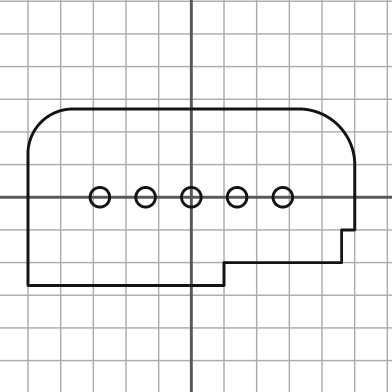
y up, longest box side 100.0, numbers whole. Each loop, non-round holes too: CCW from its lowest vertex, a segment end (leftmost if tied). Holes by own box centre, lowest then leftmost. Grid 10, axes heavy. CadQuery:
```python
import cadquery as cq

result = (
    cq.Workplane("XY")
    .moveTo(-50.0, -27.0)
    .lineTo(10.0, -27.0)
    .lineTo(10.0, -20.0)
    .lineTo(46.0, -20.0)
    .lineTo(46.0, -10.0)
    .lineTo(50.0, -10.0)
    .lineTo(50.0, 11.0)
    .threePointArc((45.0, 22.0), (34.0, 27.0))
    .lineTo(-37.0, 27.0)
    .threePointArc((-46.0, 23.0), (-50.0, 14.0))
    .close()
    .moveTo(-28.0, 0.0)
    .circle(3.0)
    .moveTo(-14.0, 0.0)
    .circle(3.0)
    .moveTo(0.0, 0.0)
    .circle(3.0)
    .moveTo(14.0, 0.0)
    .circle(3.0)
    .moveTo(28.0, 0.0)
    .circle(3.0)
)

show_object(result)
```